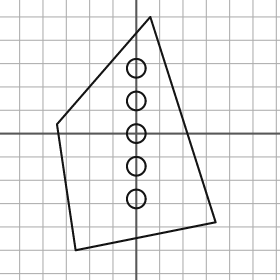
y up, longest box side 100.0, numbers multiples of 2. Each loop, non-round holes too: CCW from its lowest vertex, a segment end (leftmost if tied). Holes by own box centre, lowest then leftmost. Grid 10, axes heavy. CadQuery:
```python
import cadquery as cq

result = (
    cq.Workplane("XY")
    .moveTo(-26.0, -50.0)
    .lineTo(34.0, -38.0)
    .lineTo(6.0, 50.0)
    .lineTo(-34.0, 4.0)
    .close()
    .moveTo(0.0, -28.0)
    .circle(4.0)
    .moveTo(0.0, -14.0)
    .circle(4.0)
    .moveTo(0.0, 0.0)
    .circle(4.0)
    .moveTo(0.0, 14.0)
    .circle(4.0)
    .moveTo(0.0, 28.0)
    .circle(4.0)
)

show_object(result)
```